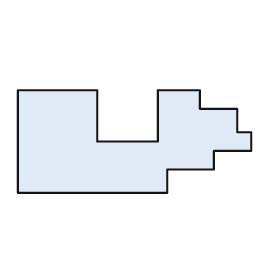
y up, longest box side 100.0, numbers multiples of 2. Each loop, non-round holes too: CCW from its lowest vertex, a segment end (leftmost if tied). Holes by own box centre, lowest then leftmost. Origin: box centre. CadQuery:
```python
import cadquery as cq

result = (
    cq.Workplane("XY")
    .moveTo(-50.0, -22.0)
    .lineTo(14.0, -22.0)
    .lineTo(14.0, -12.0)
    .lineTo(34.0, -12.0)
    .lineTo(34.0, -4.0)
    .lineTo(50.0, -4.0)
    .lineTo(50.0, 4.0)
    .lineTo(44.0, 4.0)
    .lineTo(44.0, 14.0)
    .lineTo(28.0, 14.0)
    .lineTo(28.0, 22.0)
    .lineTo(10.0, 22.0)
    .lineTo(10.0, 0.0)
    .lineTo(-16.0, 0.0)
    .lineTo(-16.0, 22.0)
    .lineTo(-50.0, 22.0)
    .close()
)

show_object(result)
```